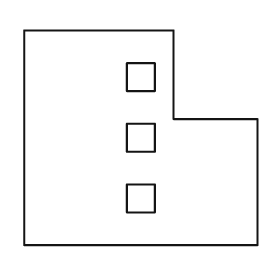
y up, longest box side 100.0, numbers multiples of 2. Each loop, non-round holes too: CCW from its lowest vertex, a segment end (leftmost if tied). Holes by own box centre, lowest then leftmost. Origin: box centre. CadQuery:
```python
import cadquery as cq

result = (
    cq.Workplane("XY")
    .moveTo(-50.0, -46.0)
    .lineTo(50.0, -46.0)
    .lineTo(50.0, 8.0)
    .lineTo(14.0, 8.0)
    .lineTo(14.0, 46.0)
    .lineTo(-50.0, 46.0)
    .close()
    .moveTo(-6.0, -32.0)
    .lineTo(6.0, -32.0)
    .lineTo(6.0, -20.0)
    .lineTo(-6.0, -20.0)
    .close()
    .moveTo(-6.0, -6.0)
    .lineTo(6.0, -6.0)
    .lineTo(6.0, 6.0)
    .lineTo(-6.0, 6.0)
    .close()
    .moveTo(-6.0, 20.0)
    .lineTo(6.0, 20.0)
    .lineTo(6.0, 32.0)
    .lineTo(-6.0, 32.0)
    .close()
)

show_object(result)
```